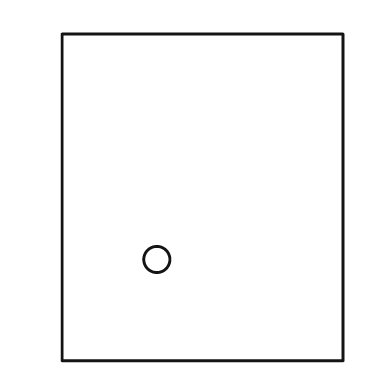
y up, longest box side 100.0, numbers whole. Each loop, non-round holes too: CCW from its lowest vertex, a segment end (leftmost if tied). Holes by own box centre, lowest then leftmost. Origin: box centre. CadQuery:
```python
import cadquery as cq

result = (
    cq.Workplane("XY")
    .moveTo(-43.0, -50.0)
    .lineTo(43.0, -50.0)
    .lineTo(43.0, 50.0)
    .lineTo(-43.0, 50.0)
    .close()
    .moveTo(-14.0, -19.0)
    .circle(4.0)
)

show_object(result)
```